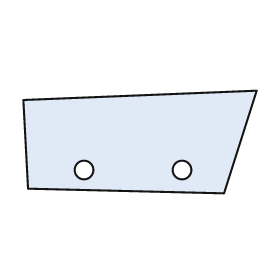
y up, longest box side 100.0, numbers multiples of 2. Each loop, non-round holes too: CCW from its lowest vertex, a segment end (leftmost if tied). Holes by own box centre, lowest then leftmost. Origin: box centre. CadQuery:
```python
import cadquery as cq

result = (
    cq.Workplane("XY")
    .moveTo(36.0, -22.0)
    .lineTo(50.0, 22.0)
    .lineTo(-50.0, 18.0)
    .lineTo(-48.0, -20.0)
    .close()
    .moveTo(-24.0, -12.0)
    .circle(4.0)
    .moveTo(18.0, -12.0)
    .circle(4.0)
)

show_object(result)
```